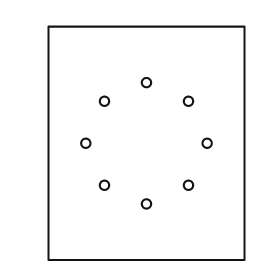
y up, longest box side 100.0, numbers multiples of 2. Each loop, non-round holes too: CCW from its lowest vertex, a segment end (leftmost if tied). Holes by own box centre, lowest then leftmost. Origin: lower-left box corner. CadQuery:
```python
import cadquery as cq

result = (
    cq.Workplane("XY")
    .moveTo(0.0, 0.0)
    .lineTo(84.0, 0.0)
    .lineTo(84.0, 100.0)
    .lineTo(0.0, 100.0)
    .close()
    .moveTo(42.0, 24.0)
    .circle(2.0)
    .moveTo(24.0, 32.0)
    .circle(2.0)
    .moveTo(60.0, 32.0)
    .circle(2.0)
    .moveTo(16.0, 50.0)
    .circle(2.0)
    .moveTo(68.0, 50.0)
    .circle(2.0)
    .moveTo(24.0, 68.0)
    .circle(2.0)
    .moveTo(60.0, 68.0)
    .circle(2.0)
    .moveTo(42.0, 76.0)
    .circle(2.0)
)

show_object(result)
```